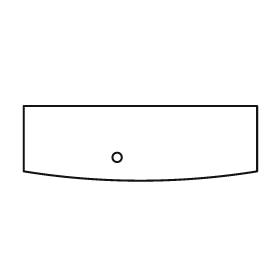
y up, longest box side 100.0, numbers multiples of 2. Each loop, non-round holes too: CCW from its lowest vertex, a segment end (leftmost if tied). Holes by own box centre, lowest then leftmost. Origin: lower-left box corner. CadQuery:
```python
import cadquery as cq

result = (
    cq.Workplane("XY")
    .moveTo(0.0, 4.0)
    .threePointArc((50.0, 0.0), (100.0, 4.0))
    .lineTo(100.0, 32.0)
    .lineTo(0.0, 32.0)
    .close()
    .moveTo(40.0, 10.0)
    .circle(2.0)
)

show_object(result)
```